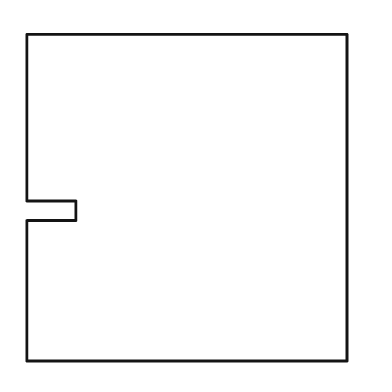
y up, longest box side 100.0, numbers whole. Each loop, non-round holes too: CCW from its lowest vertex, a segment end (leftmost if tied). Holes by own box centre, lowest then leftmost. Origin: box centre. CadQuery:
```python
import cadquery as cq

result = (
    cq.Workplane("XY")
    .moveTo(-49.0, -50.0)
    .lineTo(49.0, -50.0)
    .lineTo(49.0, 50.0)
    .lineTo(-49.0, 50.0)
    .lineTo(-49.0, -1.0)
    .lineTo(-34.0, -1.0)
    .lineTo(-34.0, -7.0)
    .lineTo(-49.0, -7.0)
    .close()
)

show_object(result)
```